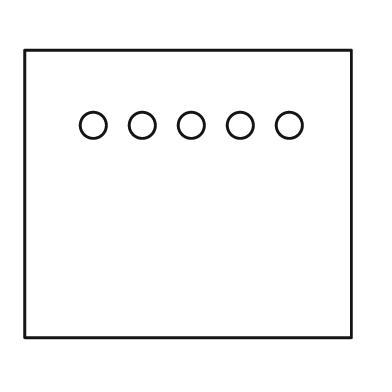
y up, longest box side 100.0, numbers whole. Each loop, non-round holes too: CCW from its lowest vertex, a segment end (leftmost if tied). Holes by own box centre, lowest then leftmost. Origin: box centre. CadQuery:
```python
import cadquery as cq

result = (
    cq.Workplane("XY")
    .moveTo(-50.0, -44.0)
    .lineTo(50.0, -44.0)
    .lineTo(50.0, 44.0)
    .lineTo(-50.0, 44.0)
    .close()
    .moveTo(-29.0, 21.0)
    .circle(4.0)
    .moveTo(-14.0, 21.0)
    .circle(4.0)
    .moveTo(1.0, 21.0)
    .circle(4.0)
    .moveTo(16.0, 21.0)
    .circle(4.0)
    .moveTo(31.0, 21.0)
    .circle(4.0)
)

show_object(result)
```